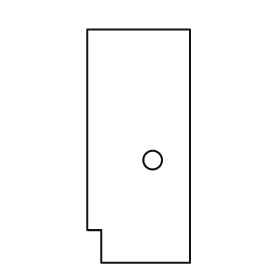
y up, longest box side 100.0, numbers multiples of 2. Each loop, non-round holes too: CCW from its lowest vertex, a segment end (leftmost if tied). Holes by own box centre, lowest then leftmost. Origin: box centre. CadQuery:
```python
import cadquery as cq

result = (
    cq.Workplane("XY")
    .moveTo(-16.0, -50.0)
    .lineTo(22.0, -50.0)
    .lineTo(22.0, 50.0)
    .lineTo(-22.0, 50.0)
    .lineTo(-22.0, -36.0)
    .lineTo(-16.0, -36.0)
    .close()
    .moveTo(6.0, -6.0)
    .circle(4.0)
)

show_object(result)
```